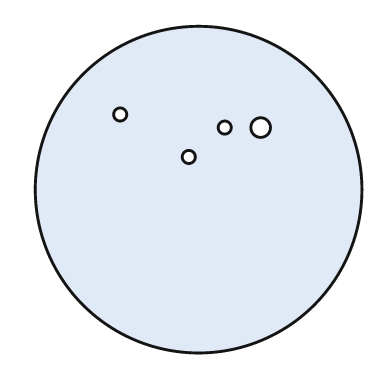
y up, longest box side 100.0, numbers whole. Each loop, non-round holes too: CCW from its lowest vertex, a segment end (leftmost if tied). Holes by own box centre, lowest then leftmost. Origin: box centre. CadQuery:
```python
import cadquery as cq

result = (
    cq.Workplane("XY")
    .moveTo(0.0, 0.0)
    .circle(50.0)
    .moveTo(-3.0, 10.0)
    .circle(2.0)
    .moveTo(8.0, 19.0)
    .circle(2.0)
    .moveTo(19.0, 19.0)
    .circle(3.0)
    .moveTo(-24.0, 23.0)
    .circle(2.0)
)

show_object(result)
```